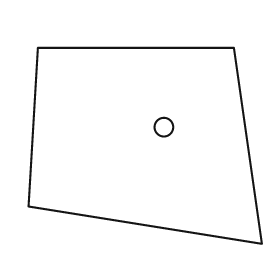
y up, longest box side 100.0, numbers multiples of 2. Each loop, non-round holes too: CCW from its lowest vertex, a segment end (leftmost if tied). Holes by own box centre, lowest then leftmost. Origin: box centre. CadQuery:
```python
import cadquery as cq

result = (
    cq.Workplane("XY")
    .moveTo(50.0, -42.0)
    .lineTo(38.0, 42.0)
    .lineTo(-46.0, 42.0)
    .lineTo(-50.0, -26.0)
    .close()
    .moveTo(8.0, 8.0)
    .circle(4.0)
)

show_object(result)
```